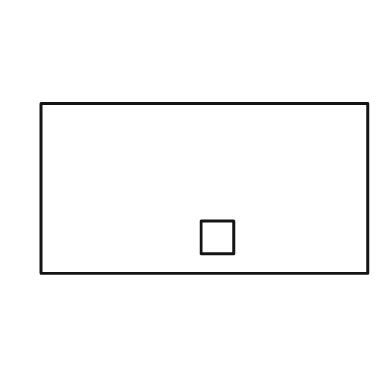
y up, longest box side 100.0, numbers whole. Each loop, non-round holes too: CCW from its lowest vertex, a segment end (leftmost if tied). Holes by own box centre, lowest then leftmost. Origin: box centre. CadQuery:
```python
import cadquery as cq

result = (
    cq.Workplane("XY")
    .moveTo(-50.0, -26.0)
    .lineTo(50.0, -26.0)
    .lineTo(50.0, 26.0)
    .lineTo(-50.0, 26.0)
    .close()
    .moveTo(-1.0, -20.0)
    .lineTo(9.0, -20.0)
    .lineTo(9.0, -10.0)
    .lineTo(-1.0, -10.0)
    .close()
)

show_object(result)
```